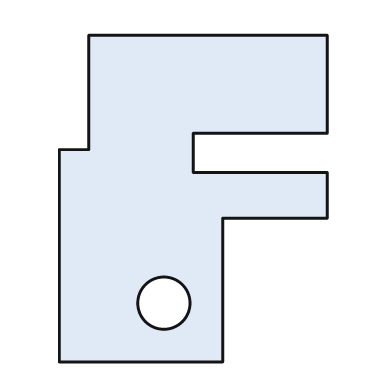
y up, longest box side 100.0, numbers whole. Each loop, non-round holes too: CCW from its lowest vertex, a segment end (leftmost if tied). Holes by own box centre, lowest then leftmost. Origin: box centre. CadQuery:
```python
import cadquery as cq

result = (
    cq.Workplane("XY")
    .moveTo(-41.0, -50.0)
    .lineTo(9.0, -50.0)
    .lineTo(9.0, -6.0)
    .lineTo(41.0, -6.0)
    .lineTo(41.0, 8.0)
    .lineTo(0.0, 8.0)
    .lineTo(0.0, 20.0)
    .lineTo(41.0, 20.0)
    .lineTo(41.0, 50.0)
    .lineTo(-32.0, 50.0)
    .lineTo(-32.0, 15.0)
    .lineTo(-41.0, 15.0)
    .close()
    .moveTo(-9.0, -32.0)
    .circle(8.0)
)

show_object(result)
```